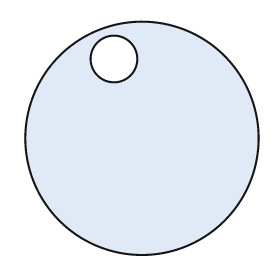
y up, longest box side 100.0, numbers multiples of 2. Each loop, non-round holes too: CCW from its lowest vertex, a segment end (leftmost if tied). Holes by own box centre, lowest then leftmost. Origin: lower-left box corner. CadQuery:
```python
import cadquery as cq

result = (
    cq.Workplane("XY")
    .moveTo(50.0, 50.0)
    .circle(50.0)
    .moveTo(38.0, 84.0)
    .circle(10.0)
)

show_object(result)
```